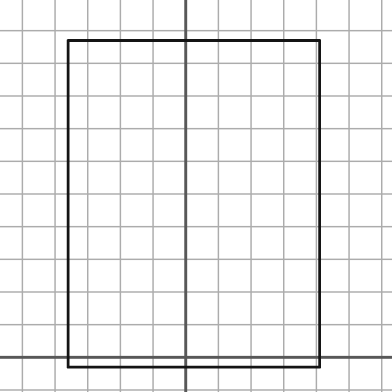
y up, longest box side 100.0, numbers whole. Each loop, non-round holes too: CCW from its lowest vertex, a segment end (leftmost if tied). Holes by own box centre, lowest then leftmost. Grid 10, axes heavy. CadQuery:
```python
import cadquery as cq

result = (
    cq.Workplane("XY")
    .moveTo(-36.0, -3.0)
    .lineTo(41.0, -3.0)
    .lineTo(41.0, 97.0)
    .lineTo(-36.0, 97.0)
    .close()
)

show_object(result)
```